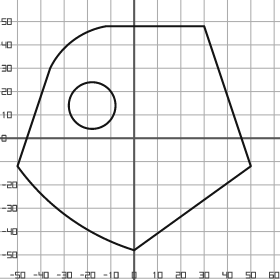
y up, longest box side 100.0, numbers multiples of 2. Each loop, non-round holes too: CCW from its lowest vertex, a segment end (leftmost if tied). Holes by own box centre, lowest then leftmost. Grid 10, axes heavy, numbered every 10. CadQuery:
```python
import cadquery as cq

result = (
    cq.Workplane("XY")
    .moveTo(0.0, -48.0)
    .lineTo(50.0, -12.0)
    .lineTo(30.0, 48.0)
    .lineTo(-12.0, 48.0)
    .threePointArc((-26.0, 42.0), (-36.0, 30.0))
    .lineTo(-50.0, -12.0)
    .threePointArc((-28.0, -34.0), (0.0, -48.0))
    .close()
    .moveTo(-18.0, 14.0)
    .circle(10.0)
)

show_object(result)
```